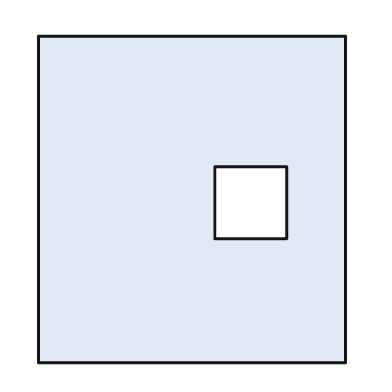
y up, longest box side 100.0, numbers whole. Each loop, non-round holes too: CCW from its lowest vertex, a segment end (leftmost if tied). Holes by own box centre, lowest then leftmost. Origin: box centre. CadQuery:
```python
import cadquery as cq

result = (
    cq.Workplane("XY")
    .moveTo(-47.0, -50.0)
    .lineTo(47.0, -50.0)
    .lineTo(47.0, 50.0)
    .lineTo(-47.0, 50.0)
    .close()
    .moveTo(7.0, -12.0)
    .lineTo(29.0, -12.0)
    .lineTo(29.0, 10.0)
    .lineTo(7.0, 10.0)
    .close()
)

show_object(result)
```